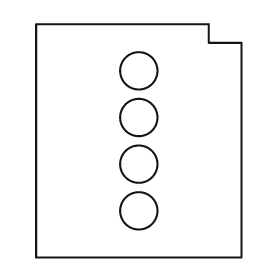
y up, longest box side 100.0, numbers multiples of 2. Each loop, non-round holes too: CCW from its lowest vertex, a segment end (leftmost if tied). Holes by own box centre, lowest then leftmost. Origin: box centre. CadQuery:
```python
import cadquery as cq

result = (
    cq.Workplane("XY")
    .moveTo(-44.0, -50.0)
    .lineTo(44.0, -50.0)
    .lineTo(44.0, 42.0)
    .lineTo(30.0, 42.0)
    .lineTo(30.0, 50.0)
    .lineTo(-44.0, 50.0)
    .close()
    .moveTo(0.0, -30.0)
    .circle(8.0)
    .moveTo(0.0, -10.0)
    .circle(8.0)
    .moveTo(0.0, 10.0)
    .circle(8.0)
    .moveTo(0.0, 30.0)
    .circle(8.0)
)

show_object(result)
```